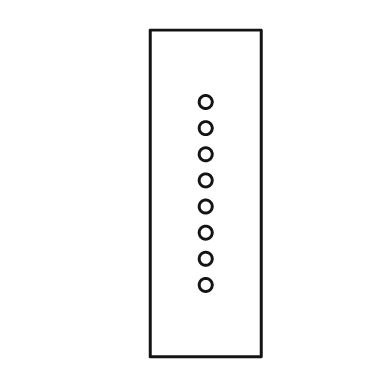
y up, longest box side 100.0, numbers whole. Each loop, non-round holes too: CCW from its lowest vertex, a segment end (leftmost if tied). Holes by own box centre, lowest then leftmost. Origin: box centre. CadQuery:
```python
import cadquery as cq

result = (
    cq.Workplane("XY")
    .moveTo(-17.0, -50.0)
    .lineTo(17.0, -50.0)
    .lineTo(17.0, 50.0)
    .lineTo(-17.0, 50.0)
    .close()
    .moveTo(0.0, -28.0)
    .circle(2.0)
    .moveTo(0.0, -20.0)
    .circle(2.0)
    .moveTo(0.0, -12.0)
    .circle(2.0)
    .moveTo(0.0, -4.0)
    .circle(2.0)
    .moveTo(0.0, 4.0)
    .circle(2.0)
    .moveTo(0.0, 12.0)
    .circle(2.0)
    .moveTo(0.0, 20.0)
    .circle(2.0)
    .moveTo(0.0, 28.0)
    .circle(2.0)
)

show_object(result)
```